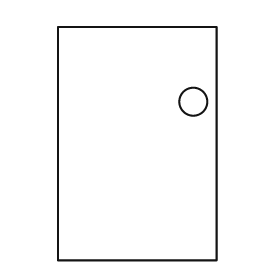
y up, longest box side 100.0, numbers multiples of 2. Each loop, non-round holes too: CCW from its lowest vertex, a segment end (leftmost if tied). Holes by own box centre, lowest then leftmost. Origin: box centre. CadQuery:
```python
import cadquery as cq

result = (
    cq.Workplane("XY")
    .moveTo(-34.0, -50.0)
    .lineTo(34.0, -50.0)
    .lineTo(34.0, 50.0)
    .lineTo(-34.0, 50.0)
    .close()
    .moveTo(24.0, 18.0)
    .circle(6.0)
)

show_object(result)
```